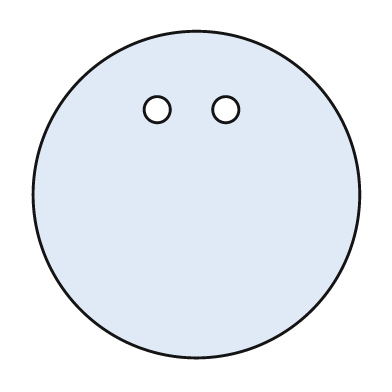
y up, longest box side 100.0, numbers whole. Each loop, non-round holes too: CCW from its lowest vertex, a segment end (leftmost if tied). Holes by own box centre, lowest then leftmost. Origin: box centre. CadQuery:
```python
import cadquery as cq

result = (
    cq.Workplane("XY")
    .moveTo(0.0, 0.0)
    .circle(50.0)
    .moveTo(-12.0, 26.0)
    .circle(4.0)
    .moveTo(9.0, 26.0)
    .circle(4.0)
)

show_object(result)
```